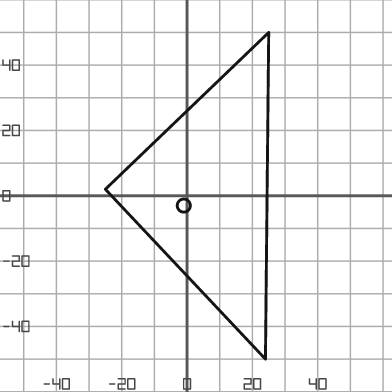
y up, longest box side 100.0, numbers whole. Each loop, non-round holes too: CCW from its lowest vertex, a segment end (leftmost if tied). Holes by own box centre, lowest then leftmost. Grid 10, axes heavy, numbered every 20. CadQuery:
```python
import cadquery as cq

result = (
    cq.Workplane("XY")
    .moveTo(24.0, -50.0)
    .lineTo(25.0, 50.0)
    .lineTo(-25.0, 2.0)
    .close()
    .moveTo(-1.0, -3.0)
    .circle(2.0)
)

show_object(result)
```